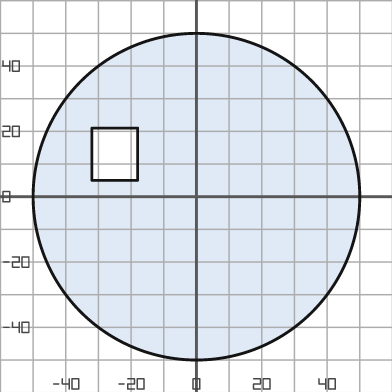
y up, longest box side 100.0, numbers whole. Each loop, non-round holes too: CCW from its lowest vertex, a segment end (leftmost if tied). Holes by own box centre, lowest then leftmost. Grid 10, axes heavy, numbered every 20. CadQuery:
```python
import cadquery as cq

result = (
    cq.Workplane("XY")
    .moveTo(0.0, 0.0)
    .circle(50.0)
    .moveTo(-32.0, 5.0)
    .lineTo(-18.0, 5.0)
    .lineTo(-18.0, 21.0)
    .lineTo(-32.0, 21.0)
    .close()
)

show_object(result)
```